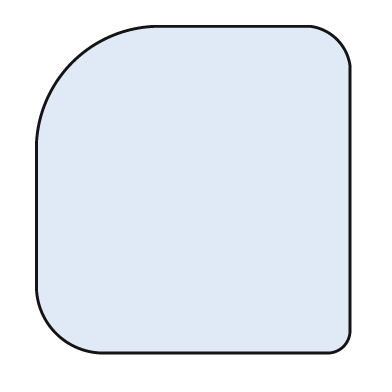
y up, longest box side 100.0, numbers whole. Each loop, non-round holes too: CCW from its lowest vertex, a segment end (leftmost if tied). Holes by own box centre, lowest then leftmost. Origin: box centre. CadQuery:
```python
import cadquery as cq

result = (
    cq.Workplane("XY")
    .moveTo(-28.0, -50.0)
    .lineTo(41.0, -50.0)
    .threePointArc((46.0, -48.0), (48.0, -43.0))
    .lineTo(48.0, 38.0)
    .threePointArc((44.0, 46.0), (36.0, 50.0))
    .lineTo(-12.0, 50.0)
    .threePointArc((-37.0, 39.0), (-48.0, 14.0))
    .lineTo(-48.0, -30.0)
    .threePointArc((-42.0, -44.0), (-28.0, -50.0))
    .close()
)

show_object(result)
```